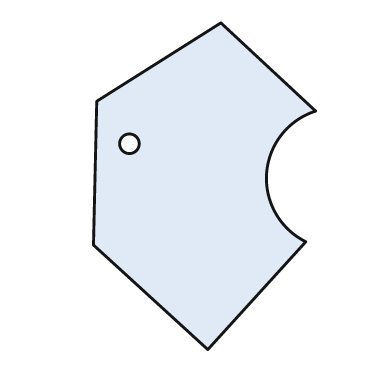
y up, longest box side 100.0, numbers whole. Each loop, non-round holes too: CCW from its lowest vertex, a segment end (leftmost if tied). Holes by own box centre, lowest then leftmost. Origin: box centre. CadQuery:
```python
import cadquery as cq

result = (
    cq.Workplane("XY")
    .moveTo(1.0, -50.0)
    .lineTo(31.0, -17.0)
    .threePointArc((19.0, 4.0), (34.0, 23.0))
    .lineTo(5.0, 50.0)
    .lineTo(-33.0, 26.0)
    .lineTo(-34.0, -18.0)
    .close()
    .moveTo(-23.0, 13.0)
    .circle(3.0)
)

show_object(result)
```